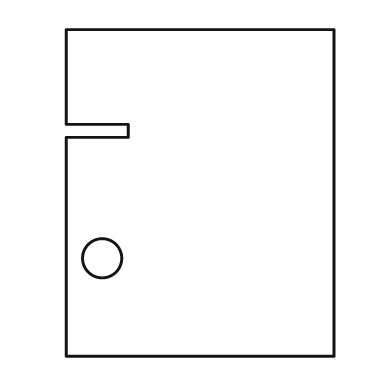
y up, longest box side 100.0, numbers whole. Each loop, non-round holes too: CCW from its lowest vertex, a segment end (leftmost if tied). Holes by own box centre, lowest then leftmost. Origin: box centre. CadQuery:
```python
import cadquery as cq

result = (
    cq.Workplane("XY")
    .moveTo(-41.0, -50.0)
    .lineTo(41.0, -50.0)
    .lineTo(41.0, 50.0)
    .lineTo(-41.0, 50.0)
    .lineTo(-41.0, 21.0)
    .lineTo(-22.0, 21.0)
    .lineTo(-22.0, 17.0)
    .lineTo(-41.0, 17.0)
    .close()
    .moveTo(-30.0, -20.0)
    .circle(6.0)
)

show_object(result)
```